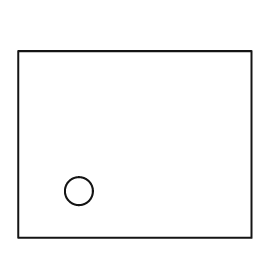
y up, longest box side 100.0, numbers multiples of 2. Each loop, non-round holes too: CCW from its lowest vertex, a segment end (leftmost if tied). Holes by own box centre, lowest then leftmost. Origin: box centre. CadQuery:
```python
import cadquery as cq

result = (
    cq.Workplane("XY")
    .moveTo(-50.0, -40.0)
    .lineTo(50.0, -40.0)
    .lineTo(50.0, 40.0)
    .lineTo(-50.0, 40.0)
    .close()
    .moveTo(-24.0, -20.0)
    .circle(6.0)
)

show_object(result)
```